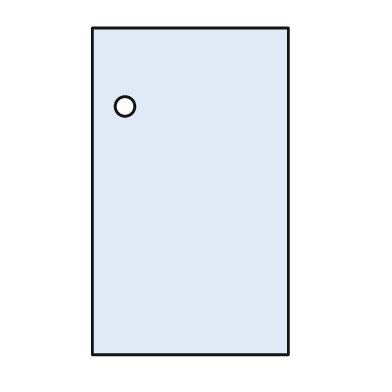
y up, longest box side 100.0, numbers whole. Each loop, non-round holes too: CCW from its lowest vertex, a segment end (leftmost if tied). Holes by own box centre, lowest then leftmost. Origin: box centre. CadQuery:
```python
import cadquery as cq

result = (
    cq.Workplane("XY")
    .moveTo(-30.0, -50.0)
    .lineTo(30.0, -50.0)
    .lineTo(30.0, 50.0)
    .lineTo(-30.0, 50.0)
    .close()
    .moveTo(-20.0, 26.0)
    .circle(3.0)
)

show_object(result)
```